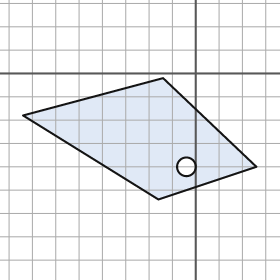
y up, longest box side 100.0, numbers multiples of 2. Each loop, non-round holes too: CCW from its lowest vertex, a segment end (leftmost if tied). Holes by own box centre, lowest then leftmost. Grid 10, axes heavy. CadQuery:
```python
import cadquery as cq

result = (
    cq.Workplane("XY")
    .moveTo(-16.0, -54.0)
    .lineTo(26.0, -40.0)
    .lineTo(-14.0, -2.0)
    .lineTo(-74.0, -18.0)
    .close()
    .moveTo(-4.0, -40.0)
    .circle(4.0)
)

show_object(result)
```